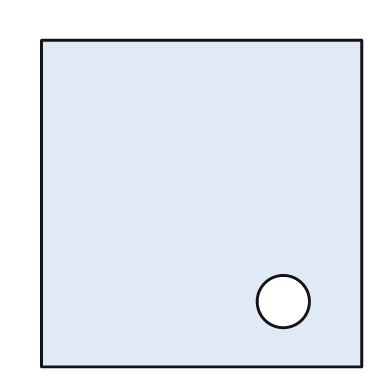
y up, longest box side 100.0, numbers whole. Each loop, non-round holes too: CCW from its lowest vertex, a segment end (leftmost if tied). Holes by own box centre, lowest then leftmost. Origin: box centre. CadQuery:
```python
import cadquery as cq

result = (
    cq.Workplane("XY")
    .moveTo(-49.0, -50.0)
    .lineTo(49.0, -50.0)
    .lineTo(49.0, 50.0)
    .lineTo(-49.0, 50.0)
    .close()
    .moveTo(25.0, -30.0)
    .circle(8.0)
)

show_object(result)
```